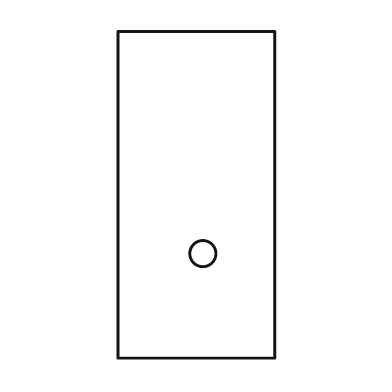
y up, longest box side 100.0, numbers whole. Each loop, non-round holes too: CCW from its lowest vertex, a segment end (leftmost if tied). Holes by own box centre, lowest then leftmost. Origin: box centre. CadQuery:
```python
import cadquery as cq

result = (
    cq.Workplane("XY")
    .moveTo(-24.0, -50.0)
    .lineTo(24.0, -50.0)
    .lineTo(24.0, 50.0)
    .lineTo(-24.0, 50.0)
    .close()
    .moveTo(2.0, -18.0)
    .circle(4.0)
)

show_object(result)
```